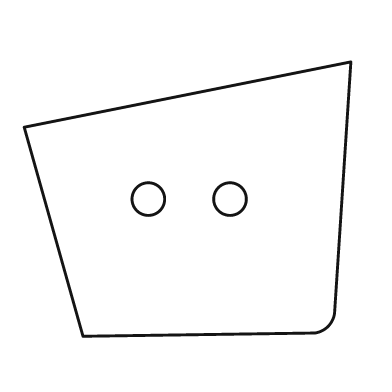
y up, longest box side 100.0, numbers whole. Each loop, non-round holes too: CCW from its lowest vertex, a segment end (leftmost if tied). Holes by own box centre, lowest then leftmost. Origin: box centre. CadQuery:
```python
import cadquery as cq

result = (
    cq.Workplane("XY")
    .moveTo(-32.0, -42.0)
    .lineTo(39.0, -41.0)
    .threePointArc((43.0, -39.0), (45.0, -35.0))
    .lineTo(50.0, 42.0)
    .lineTo(-50.0, 22.0)
    .close()
    .moveTo(-12.0, 0.0)
    .circle(5.0)
    .moveTo(13.0, 0.0)
    .circle(5.0)
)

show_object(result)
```